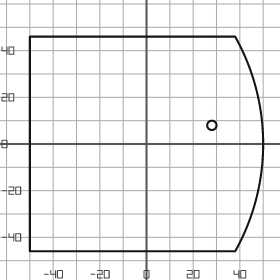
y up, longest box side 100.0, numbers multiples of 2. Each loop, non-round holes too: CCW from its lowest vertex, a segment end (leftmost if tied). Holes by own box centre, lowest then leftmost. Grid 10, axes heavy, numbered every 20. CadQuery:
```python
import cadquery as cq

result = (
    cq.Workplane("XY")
    .moveTo(-50.0, -46.0)
    .lineTo(38.0, -46.0)
    .threePointArc((50.0, 0.0), (38.0, 46.0))
    .lineTo(-50.0, 46.0)
    .close()
    .moveTo(28.0, 8.0)
    .circle(2.0)
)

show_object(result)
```